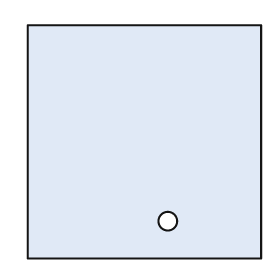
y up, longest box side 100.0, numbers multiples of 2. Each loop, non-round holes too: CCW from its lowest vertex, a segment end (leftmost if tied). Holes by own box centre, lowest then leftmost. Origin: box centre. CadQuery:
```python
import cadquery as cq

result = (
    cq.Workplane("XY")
    .moveTo(-50.0, -50.0)
    .lineTo(50.0, -50.0)
    .lineTo(50.0, 50.0)
    .lineTo(-50.0, 50.0)
    .close()
    .moveTo(10.0, -34.0)
    .circle(4.0)
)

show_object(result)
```